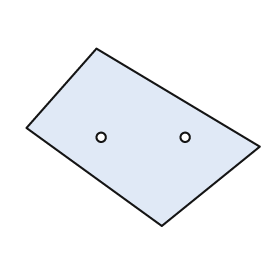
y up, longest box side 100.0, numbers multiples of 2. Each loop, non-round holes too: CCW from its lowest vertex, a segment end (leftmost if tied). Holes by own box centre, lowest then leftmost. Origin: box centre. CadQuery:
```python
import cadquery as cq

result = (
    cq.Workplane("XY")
    .moveTo(8.0, -38.0)
    .lineTo(50.0, -4.0)
    .lineTo(-20.0, 38.0)
    .lineTo(-50.0, 4.0)
    .close()
    .moveTo(-18.0, 0.0)
    .circle(2.0)
    .moveTo(18.0, 0.0)
    .circle(2.0)
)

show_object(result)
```